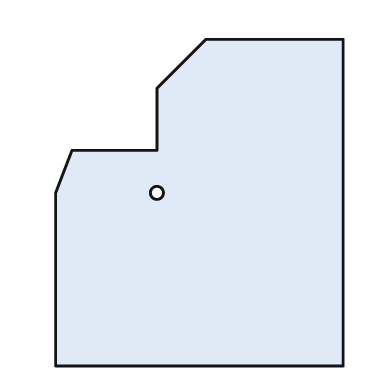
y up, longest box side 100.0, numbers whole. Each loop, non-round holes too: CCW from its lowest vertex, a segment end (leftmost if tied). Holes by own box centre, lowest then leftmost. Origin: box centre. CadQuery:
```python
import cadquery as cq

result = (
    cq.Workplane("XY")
    .moveTo(-44.0, -50.0)
    .lineTo(44.0, -50.0)
    .lineTo(44.0, 50.0)
    .lineTo(2.0, 50.0)
    .lineTo(-13.0, 35.0)
    .lineTo(-13.0, 16.0)
    .lineTo(-39.0, 16.0)
    .lineTo(-44.0, 3.0)
    .close()
    .moveTo(-13.0, 3.0)
    .circle(2.0)
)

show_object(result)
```